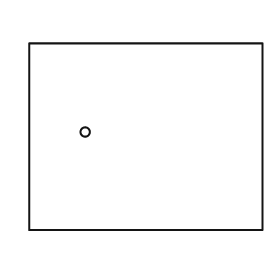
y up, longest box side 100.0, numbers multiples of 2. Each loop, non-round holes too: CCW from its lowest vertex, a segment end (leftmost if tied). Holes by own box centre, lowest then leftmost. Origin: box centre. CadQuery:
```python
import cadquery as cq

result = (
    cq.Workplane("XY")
    .moveTo(-50.0, -40.0)
    .lineTo(50.0, -40.0)
    .lineTo(50.0, 40.0)
    .lineTo(-50.0, 40.0)
    .close()
    .moveTo(-26.0, 2.0)
    .circle(2.0)
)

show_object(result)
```